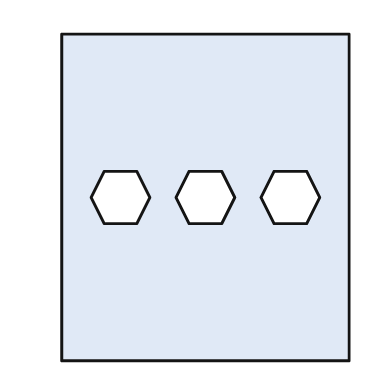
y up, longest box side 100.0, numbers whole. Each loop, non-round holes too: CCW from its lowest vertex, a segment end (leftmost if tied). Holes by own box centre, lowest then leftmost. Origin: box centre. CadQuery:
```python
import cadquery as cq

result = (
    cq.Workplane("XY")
    .moveTo(-44.0, -50.0)
    .lineTo(44.0, -50.0)
    .lineTo(44.0, 50.0)
    .lineTo(-44.0, 50.0)
    .close()
    .moveTo(-31.0, -8.0)
    .lineTo(-21.0, -8.0)
    .lineTo(-17.0, 0.0)
    .lineTo(-21.0, 8.0)
    .lineTo(-31.0, 8.0)
    .lineTo(-35.0, 0.0)
    .close()
    .moveTo(-5.0, -8.0)
    .lineTo(5.0, -8.0)
    .lineTo(9.0, 0.0)
    .lineTo(5.0, 8.0)
    .lineTo(-5.0, 8.0)
    .lineTo(-9.0, 0.0)
    .close()
    .moveTo(21.0, -8.0)
    .lineTo(31.0, -8.0)
    .lineTo(35.0, 0.0)
    .lineTo(31.0, 8.0)
    .lineTo(21.0, 8.0)
    .lineTo(17.0, 0.0)
    .close()
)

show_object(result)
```